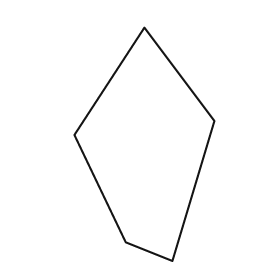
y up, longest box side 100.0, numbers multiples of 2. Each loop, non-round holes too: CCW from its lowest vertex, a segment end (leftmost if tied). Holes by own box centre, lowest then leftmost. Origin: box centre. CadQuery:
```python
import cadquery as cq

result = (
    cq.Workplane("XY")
    .moveTo(12.0, -50.0)
    .lineTo(30.0, 10.0)
    .lineTo(0.0, 50.0)
    .lineTo(-30.0, 4.0)
    .lineTo(-8.0, -42.0)
    .close()
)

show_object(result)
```